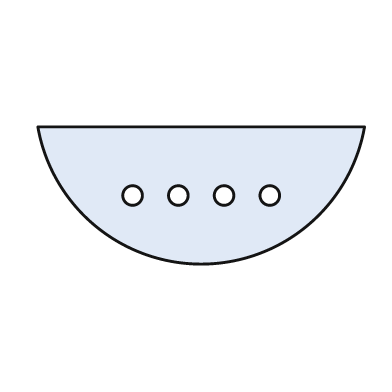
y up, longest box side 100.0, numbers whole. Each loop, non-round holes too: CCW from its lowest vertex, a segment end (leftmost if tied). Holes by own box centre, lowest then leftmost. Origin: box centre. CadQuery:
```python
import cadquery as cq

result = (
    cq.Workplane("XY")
    .moveTo(-50.0, 21.0)
    .threePointArc((0.0, -21.0), (50.0, 21.0))
    .close()
    .moveTo(-21.0, 0.0)
    .circle(3.0)
    .moveTo(-7.0, 0.0)
    .circle(3.0)
    .moveTo(7.0, 0.0)
    .circle(3.0)
    .moveTo(21.0, 0.0)
    .circle(3.0)
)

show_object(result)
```